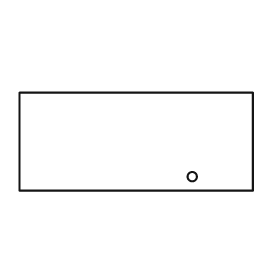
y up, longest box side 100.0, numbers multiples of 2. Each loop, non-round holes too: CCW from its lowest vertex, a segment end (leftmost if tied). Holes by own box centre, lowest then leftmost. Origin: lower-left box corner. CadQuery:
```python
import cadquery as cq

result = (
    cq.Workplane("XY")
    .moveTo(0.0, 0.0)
    .lineTo(100.0, 0.0)
    .lineTo(100.0, 42.0)
    .lineTo(0.0, 42.0)
    .close()
    .moveTo(74.0, 6.0)
    .circle(2.0)
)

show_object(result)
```